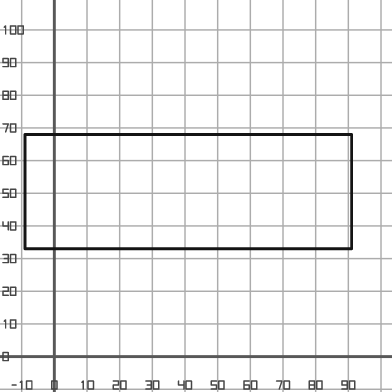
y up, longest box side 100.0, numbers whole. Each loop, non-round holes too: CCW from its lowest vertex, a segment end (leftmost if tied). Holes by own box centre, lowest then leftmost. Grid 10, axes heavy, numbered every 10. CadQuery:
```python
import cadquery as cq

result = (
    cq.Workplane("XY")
    .moveTo(-9.0, 33.0)
    .lineTo(91.0, 33.0)
    .lineTo(91.0, 68.0)
    .lineTo(-9.0, 68.0)
    .close()
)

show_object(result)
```